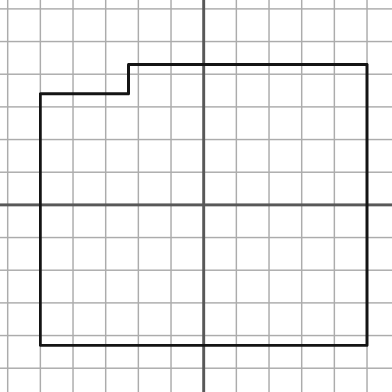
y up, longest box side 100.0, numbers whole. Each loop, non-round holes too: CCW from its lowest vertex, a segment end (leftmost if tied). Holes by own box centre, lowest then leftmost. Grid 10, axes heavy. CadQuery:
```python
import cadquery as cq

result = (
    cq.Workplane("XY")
    .moveTo(-50.0, -43.0)
    .lineTo(50.0, -43.0)
    .lineTo(50.0, 43.0)
    .lineTo(-23.0, 43.0)
    .lineTo(-23.0, 34.0)
    .lineTo(-50.0, 34.0)
    .close()
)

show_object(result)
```